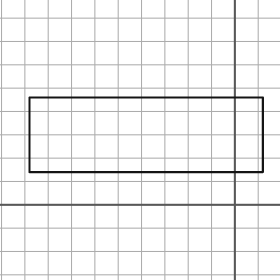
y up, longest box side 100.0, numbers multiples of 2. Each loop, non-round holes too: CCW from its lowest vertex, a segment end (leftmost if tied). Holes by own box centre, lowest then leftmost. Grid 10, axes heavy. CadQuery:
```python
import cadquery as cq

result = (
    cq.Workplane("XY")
    .moveTo(-88.0, 14.0)
    .lineTo(12.0, 14.0)
    .lineTo(12.0, 46.0)
    .lineTo(-88.0, 46.0)
    .close()
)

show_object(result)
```